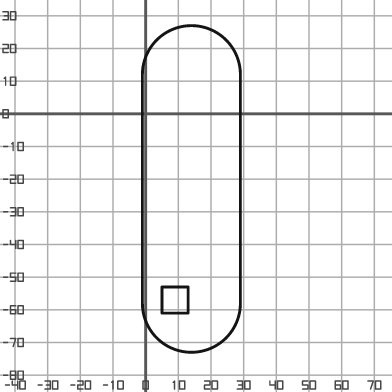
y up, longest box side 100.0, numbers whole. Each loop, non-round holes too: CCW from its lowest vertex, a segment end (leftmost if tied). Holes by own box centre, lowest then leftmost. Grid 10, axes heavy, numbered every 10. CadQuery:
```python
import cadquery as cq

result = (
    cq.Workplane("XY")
    .moveTo(-1.0, -58.0)
    .threePointArc((14.0, -73.0), (29.0, -58.0))
    .lineTo(29.0, 12.0)
    .threePointArc((14.0, 27.0), (-1.0, 12.0))
    .close()
    .moveTo(5.0, -61.0)
    .lineTo(13.0, -61.0)
    .lineTo(13.0, -53.0)
    .lineTo(5.0, -53.0)
    .close()
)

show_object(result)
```